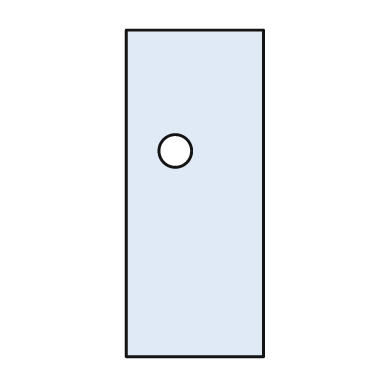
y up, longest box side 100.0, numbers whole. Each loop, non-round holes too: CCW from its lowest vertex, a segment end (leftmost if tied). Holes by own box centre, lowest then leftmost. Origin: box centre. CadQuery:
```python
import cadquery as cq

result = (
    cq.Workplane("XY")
    .moveTo(-21.0, -50.0)
    .lineTo(21.0, -50.0)
    .lineTo(21.0, 50.0)
    .lineTo(-21.0, 50.0)
    .close()
    .moveTo(-6.0, 13.0)
    .circle(5.0)
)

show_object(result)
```